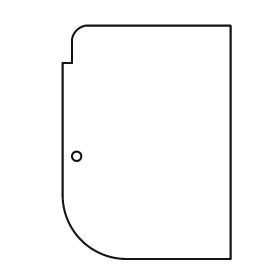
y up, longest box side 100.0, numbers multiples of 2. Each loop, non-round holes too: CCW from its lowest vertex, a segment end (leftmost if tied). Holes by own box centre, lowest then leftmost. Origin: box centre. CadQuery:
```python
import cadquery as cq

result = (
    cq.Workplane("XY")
    .moveTo(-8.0, -50.0)
    .lineTo(36.0, -50.0)
    .lineTo(36.0, 50.0)
    .lineTo(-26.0, 50.0)
    .threePointArc((-30.0, 48.0), (-32.0, 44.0))
    .lineTo(-32.0, 34.0)
    .lineTo(-36.0, 34.0)
    .lineTo(-36.0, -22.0)
    .threePointArc((-28.0, -42.0), (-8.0, -50.0))
    .close()
    .moveTo(-30.0, -6.0)
    .circle(2.0)
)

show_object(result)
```